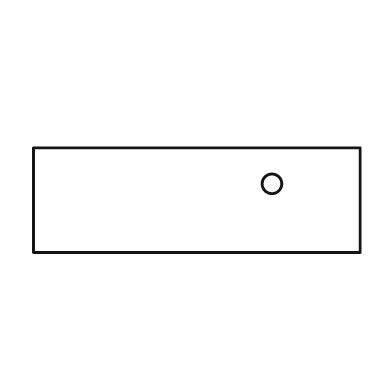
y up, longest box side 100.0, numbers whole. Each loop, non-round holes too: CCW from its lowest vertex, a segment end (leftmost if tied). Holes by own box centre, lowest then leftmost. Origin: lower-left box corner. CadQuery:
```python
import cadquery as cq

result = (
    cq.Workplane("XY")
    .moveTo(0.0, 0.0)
    .lineTo(100.0, 0.0)
    .lineTo(100.0, 32.0)
    .lineTo(0.0, 32.0)
    .close()
    .moveTo(73.0, 21.0)
    .circle(3.0)
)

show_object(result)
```